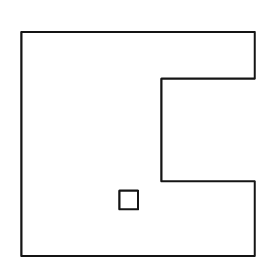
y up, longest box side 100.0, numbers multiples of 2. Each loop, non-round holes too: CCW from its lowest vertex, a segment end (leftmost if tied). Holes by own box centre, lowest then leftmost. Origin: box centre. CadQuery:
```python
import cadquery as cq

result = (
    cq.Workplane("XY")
    .moveTo(-50.0, -48.0)
    .lineTo(50.0, -48.0)
    .lineTo(50.0, -16.0)
    .lineTo(10.0, -16.0)
    .lineTo(10.0, 28.0)
    .lineTo(50.0, 28.0)
    .lineTo(50.0, 48.0)
    .lineTo(-50.0, 48.0)
    .close()
    .moveTo(-8.0, -28.0)
    .lineTo(0.0, -28.0)
    .lineTo(0.0, -20.0)
    .lineTo(-8.0, -20.0)
    .close()
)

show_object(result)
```